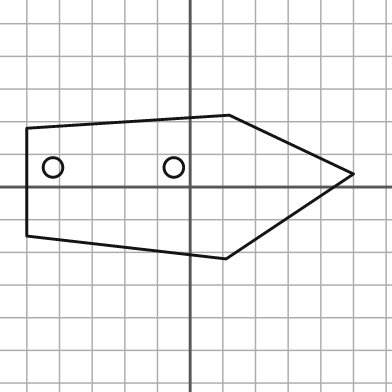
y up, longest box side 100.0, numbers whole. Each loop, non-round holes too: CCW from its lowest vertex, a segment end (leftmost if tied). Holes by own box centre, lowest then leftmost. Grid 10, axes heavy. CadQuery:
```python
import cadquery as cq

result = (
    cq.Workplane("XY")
    .moveTo(11.0, -22.0)
    .lineTo(50.0, 4.0)
    .lineTo(12.0, 22.0)
    .lineTo(-50.0, 18.0)
    .lineTo(-50.0, -15.0)
    .close()
    .moveTo(-42.0, 6.0)
    .circle(3.0)
    .moveTo(-5.0, 6.0)
    .circle(3.0)
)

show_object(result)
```